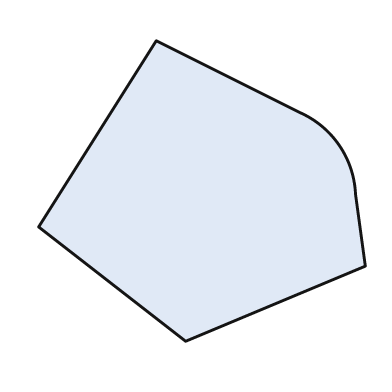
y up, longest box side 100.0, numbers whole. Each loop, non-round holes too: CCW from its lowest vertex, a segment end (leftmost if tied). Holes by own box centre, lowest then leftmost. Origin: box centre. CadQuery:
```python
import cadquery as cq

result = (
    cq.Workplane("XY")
    .moveTo(-5.0, -46.0)
    .lineTo(50.0, -23.0)
    .lineTo(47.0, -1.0)
    .threePointArc((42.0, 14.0), (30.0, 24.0))
    .lineTo(-14.0, 46.0)
    .lineTo(-50.0, -11.0)
    .close()
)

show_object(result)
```